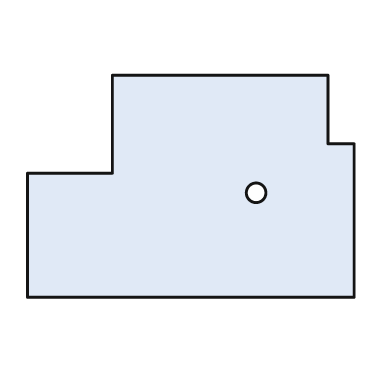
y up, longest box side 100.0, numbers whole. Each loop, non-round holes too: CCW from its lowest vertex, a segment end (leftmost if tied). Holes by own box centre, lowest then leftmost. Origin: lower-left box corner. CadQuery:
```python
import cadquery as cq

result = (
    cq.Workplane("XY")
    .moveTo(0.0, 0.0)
    .lineTo(100.0, 0.0)
    .lineTo(100.0, 47.0)
    .lineTo(92.0, 47.0)
    .lineTo(92.0, 68.0)
    .lineTo(26.0, 68.0)
    .lineTo(26.0, 38.0)
    .lineTo(0.0, 38.0)
    .close()
    .moveTo(70.0, 32.0)
    .circle(3.0)
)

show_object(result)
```